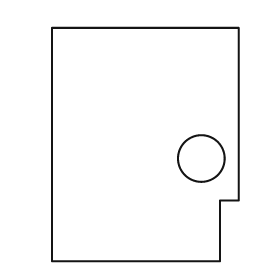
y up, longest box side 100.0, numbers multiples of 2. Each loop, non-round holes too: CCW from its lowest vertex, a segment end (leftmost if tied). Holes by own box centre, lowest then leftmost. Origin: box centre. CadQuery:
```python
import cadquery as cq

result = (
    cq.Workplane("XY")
    .moveTo(-40.0, -50.0)
    .lineTo(32.0, -50.0)
    .lineTo(32.0, -24.0)
    .lineTo(40.0, -24.0)
    .lineTo(40.0, 50.0)
    .lineTo(-40.0, 50.0)
    .close()
    .moveTo(24.0, -6.0)
    .circle(10.0)
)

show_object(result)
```